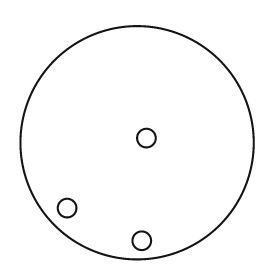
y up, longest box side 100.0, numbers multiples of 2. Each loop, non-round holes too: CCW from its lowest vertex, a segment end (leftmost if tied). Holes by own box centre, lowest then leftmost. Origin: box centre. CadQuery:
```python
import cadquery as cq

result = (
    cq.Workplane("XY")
    .moveTo(0.0, 0.0)
    .circle(50.0)
    .moveTo(2.0, -42.0)
    .circle(4.0)
    .moveTo(-30.0, -28.0)
    .circle(4.0)
    .moveTo(4.0, 2.0)
    .circle(4.0)
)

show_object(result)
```